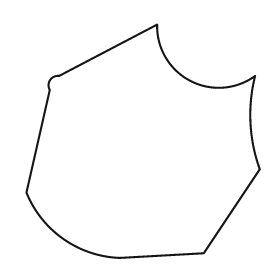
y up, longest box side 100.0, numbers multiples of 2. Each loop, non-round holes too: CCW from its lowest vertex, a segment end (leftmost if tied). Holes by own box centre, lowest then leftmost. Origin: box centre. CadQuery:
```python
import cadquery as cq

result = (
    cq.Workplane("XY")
    .moveTo(-10.0, -50.0)
    .lineTo(26.0, -48.0)
    .lineTo(50.0, -12.0)
    .threePointArc((46.0, 8.0), (48.0, 28.0))
    .threePointArc((20.0, 26.0), (6.0, 50.0))
    .lineTo(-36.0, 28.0)
    .threePointArc((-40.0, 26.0), (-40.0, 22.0))
    .lineTo(-50.0, -22.0)
    .threePointArc((-34.0, -42.0), (-10.0, -50.0))
    .close()
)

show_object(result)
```